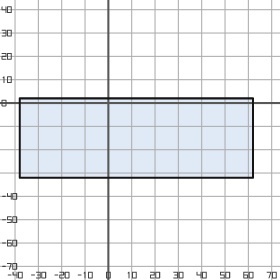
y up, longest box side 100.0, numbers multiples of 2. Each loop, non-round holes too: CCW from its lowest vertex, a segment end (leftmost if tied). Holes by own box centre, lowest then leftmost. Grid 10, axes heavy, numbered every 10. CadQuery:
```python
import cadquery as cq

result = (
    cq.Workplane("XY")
    .moveTo(-38.0, -32.0)
    .lineTo(62.0, -32.0)
    .lineTo(62.0, 2.0)
    .lineTo(-38.0, 2.0)
    .close()
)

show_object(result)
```